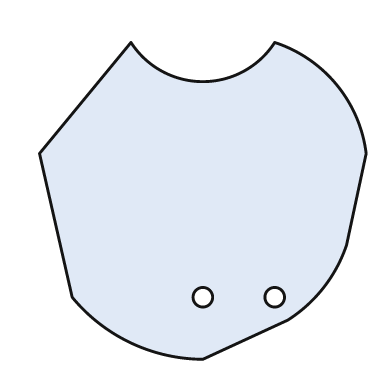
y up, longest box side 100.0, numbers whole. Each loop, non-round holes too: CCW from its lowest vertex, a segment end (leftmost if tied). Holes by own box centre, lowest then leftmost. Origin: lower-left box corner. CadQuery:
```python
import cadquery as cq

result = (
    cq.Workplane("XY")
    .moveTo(50.0, 0.0)
    .lineTo(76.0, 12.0)
    .threePointArc((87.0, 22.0), (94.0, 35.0))
    .lineTo(100.0, 63.0)
    .threePointArc((91.0, 84.0), (72.0, 97.0))
    .threePointArc((50.0, 85.0), (28.0, 97.0))
    .lineTo(0.0, 63.0)
    .lineTo(10.0, 19.0)
    .threePointArc((28.0, 5.0), (50.0, 0.0))
    .close()
    .moveTo(50.0, 19.0)
    .circle(3.0)
    .moveTo(72.0, 19.0)
    .circle(3.0)
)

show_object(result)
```